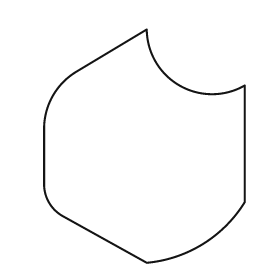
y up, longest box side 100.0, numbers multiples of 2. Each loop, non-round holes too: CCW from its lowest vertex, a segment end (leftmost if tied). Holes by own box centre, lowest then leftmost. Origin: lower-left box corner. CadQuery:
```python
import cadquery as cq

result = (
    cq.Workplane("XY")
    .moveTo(44.0, 0.0)
    .threePointArc((68.0, 8.0), (86.0, 26.0))
    .lineTo(86.0, 76.0)
    .threePointArc((58.0, 76.0), (44.0, 100.0))
    .lineTo(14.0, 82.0)
    .threePointArc((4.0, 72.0), (0.0, 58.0))
    .lineTo(0.0, 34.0)
    .threePointArc((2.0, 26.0), (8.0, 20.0))
    .close()
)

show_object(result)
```